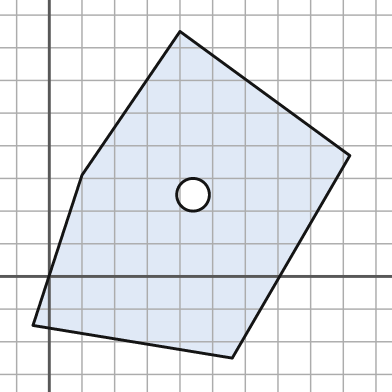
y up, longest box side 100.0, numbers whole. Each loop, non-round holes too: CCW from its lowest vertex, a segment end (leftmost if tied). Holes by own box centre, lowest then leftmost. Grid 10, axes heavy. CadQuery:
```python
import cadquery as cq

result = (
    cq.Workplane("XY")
    .moveTo(56.0, -25.0)
    .lineTo(92.0, 37.0)
    .lineTo(40.0, 75.0)
    .lineTo(10.0, 31.0)
    .lineTo(-5.0, -15.0)
    .close()
    .moveTo(44.0, 25.0)
    .circle(5.0)
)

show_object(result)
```